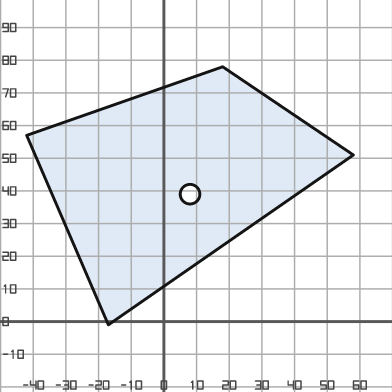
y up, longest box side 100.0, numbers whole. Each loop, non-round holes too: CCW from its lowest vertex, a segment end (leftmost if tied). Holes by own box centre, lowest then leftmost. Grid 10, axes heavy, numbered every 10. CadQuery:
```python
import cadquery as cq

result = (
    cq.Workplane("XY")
    .moveTo(-17.0, -1.0)
    .lineTo(58.0, 51.0)
    .lineTo(18.0, 78.0)
    .lineTo(-42.0, 57.0)
    .close()
    .moveTo(8.0, 39.0)
    .circle(3.0)
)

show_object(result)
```